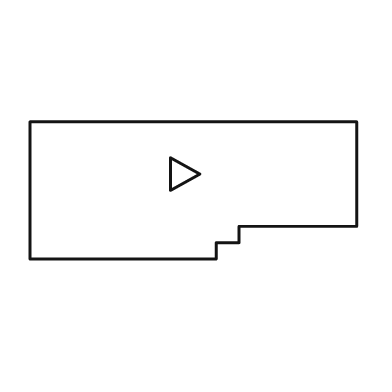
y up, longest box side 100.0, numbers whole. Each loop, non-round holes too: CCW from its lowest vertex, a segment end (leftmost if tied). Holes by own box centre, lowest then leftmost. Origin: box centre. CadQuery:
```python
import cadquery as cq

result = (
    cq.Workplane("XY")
    .moveTo(-50.0, -21.0)
    .lineTo(7.0, -21.0)
    .lineTo(7.0, -16.0)
    .lineTo(14.0, -16.0)
    .lineTo(14.0, -11.0)
    .lineTo(50.0, -11.0)
    .lineTo(50.0, 21.0)
    .lineTo(-50.0, 21.0)
    .close()
    .moveTo(-7.0, 0.0)
    .lineTo(2.0, 5.0)
    .lineTo(-7.0, 10.0)
    .close()
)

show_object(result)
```